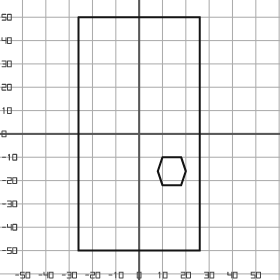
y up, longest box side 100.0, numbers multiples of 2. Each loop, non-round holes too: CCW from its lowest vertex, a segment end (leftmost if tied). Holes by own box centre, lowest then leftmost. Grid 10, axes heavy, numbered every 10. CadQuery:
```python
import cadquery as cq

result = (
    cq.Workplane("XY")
    .moveTo(-26.0, -50.0)
    .lineTo(26.0, -50.0)
    .lineTo(26.0, 50.0)
    .lineTo(-26.0, 50.0)
    .close()
    .moveTo(10.0, -22.0)
    .lineTo(18.0, -22.0)
    .lineTo(20.0, -16.0)
    .lineTo(18.0, -10.0)
    .lineTo(10.0, -10.0)
    .lineTo(8.0, -16.0)
    .close()
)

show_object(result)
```